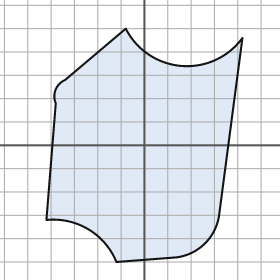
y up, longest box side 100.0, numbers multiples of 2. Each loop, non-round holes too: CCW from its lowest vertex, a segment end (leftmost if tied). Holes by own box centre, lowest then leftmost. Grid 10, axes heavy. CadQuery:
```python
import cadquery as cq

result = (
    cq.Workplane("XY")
    .moveTo(-12.0, -50.0)
    .lineTo(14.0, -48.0)
    .threePointArc((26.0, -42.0), (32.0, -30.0))
    .lineTo(42.0, 46.0)
    .threePointArc((16.0, 34.0), (-8.0, 50.0))
    .lineTo(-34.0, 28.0)
    .threePointArc((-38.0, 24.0), (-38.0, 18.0))
    .lineTo(-42.0, -32.0)
    .threePointArc((-24.0, -36.0), (-12.0, -50.0))
    .close()
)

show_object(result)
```